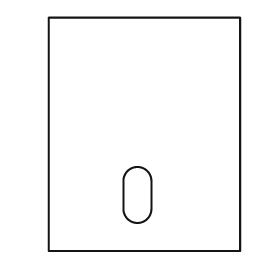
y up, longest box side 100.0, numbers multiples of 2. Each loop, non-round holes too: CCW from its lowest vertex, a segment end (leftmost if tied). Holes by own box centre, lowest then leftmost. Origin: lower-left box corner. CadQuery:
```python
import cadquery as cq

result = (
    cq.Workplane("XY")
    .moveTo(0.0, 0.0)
    .lineTo(82.0, 0.0)
    .lineTo(82.0, 100.0)
    .lineTo(0.0, 100.0)
    .close()
    .moveTo(32.0, 18.0)
    .threePointArc((38.0, 12.0), (44.0, 18.0))
    .lineTo(44.0, 30.0)
    .threePointArc((38.0, 36.0), (32.0, 30.0))
    .close()
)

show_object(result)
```